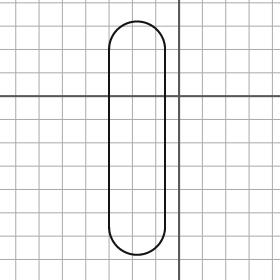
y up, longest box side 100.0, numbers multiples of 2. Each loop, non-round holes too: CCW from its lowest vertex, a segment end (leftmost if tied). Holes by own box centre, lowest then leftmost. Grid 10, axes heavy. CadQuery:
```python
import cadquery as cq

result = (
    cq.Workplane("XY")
    .moveTo(-30.0, -56.0)
    .threePointArc((-18.0, -68.0), (-6.0, -56.0))
    .lineTo(-6.0, 20.0)
    .threePointArc((-18.0, 32.0), (-30.0, 20.0))
    .close()
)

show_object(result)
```